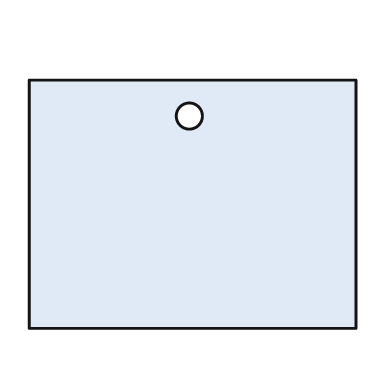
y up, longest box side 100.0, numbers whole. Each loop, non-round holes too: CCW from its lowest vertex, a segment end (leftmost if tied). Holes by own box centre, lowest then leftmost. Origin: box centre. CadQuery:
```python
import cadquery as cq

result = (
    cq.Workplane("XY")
    .moveTo(-50.0, -38.0)
    .lineTo(50.0, -38.0)
    .lineTo(50.0, 38.0)
    .lineTo(-50.0, 38.0)
    .close()
    .moveTo(-1.0, 27.0)
    .circle(4.0)
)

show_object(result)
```